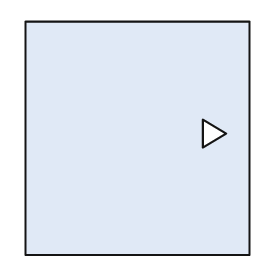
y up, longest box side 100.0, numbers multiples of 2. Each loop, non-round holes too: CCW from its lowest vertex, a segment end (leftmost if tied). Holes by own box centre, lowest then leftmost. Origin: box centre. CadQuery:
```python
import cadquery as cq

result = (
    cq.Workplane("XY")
    .moveTo(-48.0, -50.0)
    .lineTo(48.0, -50.0)
    .lineTo(48.0, 50.0)
    .lineTo(-48.0, 50.0)
    .close()
    .moveTo(28.0, -4.0)
    .lineTo(38.0, 2.0)
    .lineTo(28.0, 8.0)
    .close()
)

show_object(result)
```